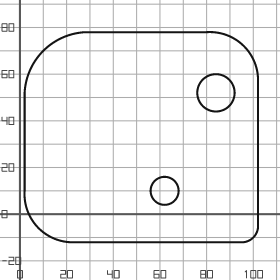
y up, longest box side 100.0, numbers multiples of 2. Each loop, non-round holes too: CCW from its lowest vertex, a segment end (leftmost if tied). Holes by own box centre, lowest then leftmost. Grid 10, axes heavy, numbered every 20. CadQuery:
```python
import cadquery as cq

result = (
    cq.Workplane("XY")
    .moveTo(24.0, -12.0)
    .lineTo(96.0, -12.0)
    .threePointArc((100.0, -10.0), (102.0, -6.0))
    .lineTo(102.0, 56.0)
    .threePointArc((96.0, 72.0), (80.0, 78.0))
    .lineTo(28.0, 78.0)
    .threePointArc((10.0, 70.0), (2.0, 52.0))
    .lineTo(2.0, 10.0)
    .threePointArc((8.0, -6.0), (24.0, -12.0))
    .close()
    .moveTo(62.0, 10.0)
    .circle(6.0)
    .moveTo(84.0, 52.0)
    .circle(8.0)
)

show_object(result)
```